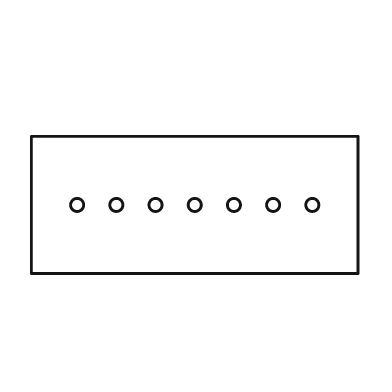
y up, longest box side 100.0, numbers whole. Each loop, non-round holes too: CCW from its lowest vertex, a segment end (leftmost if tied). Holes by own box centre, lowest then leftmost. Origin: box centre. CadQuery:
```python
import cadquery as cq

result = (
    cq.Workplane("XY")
    .moveTo(-50.0, -21.0)
    .lineTo(50.0, -21.0)
    .lineTo(50.0, 21.0)
    .lineTo(-50.0, 21.0)
    .close()
    .moveTo(-36.0, 0.0)
    .circle(2.0)
    .moveTo(-24.0, 0.0)
    .circle(2.0)
    .moveTo(-12.0, 0.0)
    .circle(2.0)
    .moveTo(0.0, 0.0)
    .circle(2.0)
    .moveTo(12.0, 0.0)
    .circle(2.0)
    .moveTo(24.0, 0.0)
    .circle(2.0)
    .moveTo(36.0, 0.0)
    .circle(2.0)
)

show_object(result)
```